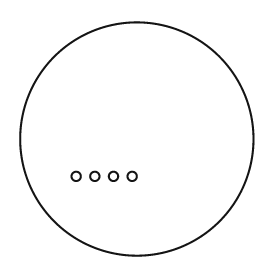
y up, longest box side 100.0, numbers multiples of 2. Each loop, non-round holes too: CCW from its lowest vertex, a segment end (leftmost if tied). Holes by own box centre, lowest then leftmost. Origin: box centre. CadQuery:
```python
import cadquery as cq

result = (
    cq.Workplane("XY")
    .moveTo(0.0, 0.0)
    .circle(50.0)
    .moveTo(-26.0, -16.0)
    .circle(2.0)
    .moveTo(-18.0, -16.0)
    .circle(2.0)
    .moveTo(-10.0, -16.0)
    .circle(2.0)
    .moveTo(-2.0, -16.0)
    .circle(2.0)
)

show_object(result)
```